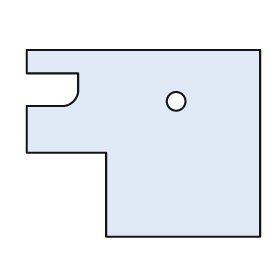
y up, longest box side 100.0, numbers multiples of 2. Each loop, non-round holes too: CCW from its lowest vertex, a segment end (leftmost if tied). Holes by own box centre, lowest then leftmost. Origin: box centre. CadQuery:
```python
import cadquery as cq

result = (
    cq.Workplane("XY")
    .moveTo(-16.0, -40.0)
    .lineTo(50.0, -40.0)
    .lineTo(50.0, 40.0)
    .lineTo(-50.0, 40.0)
    .lineTo(-50.0, 30.0)
    .lineTo(-28.0, 30.0)
    .lineTo(-28.0, 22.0)
    .threePointArc((-30.0, 18.0), (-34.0, 16.0))
    .lineTo(-50.0, 16.0)
    .lineTo(-50.0, -4.0)
    .lineTo(-16.0, -4.0)
    .close()
    .moveTo(14.0, 18.0)
    .circle(4.0)
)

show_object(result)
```